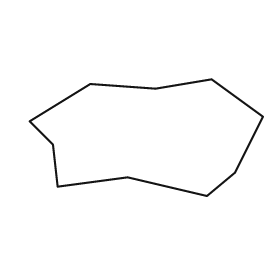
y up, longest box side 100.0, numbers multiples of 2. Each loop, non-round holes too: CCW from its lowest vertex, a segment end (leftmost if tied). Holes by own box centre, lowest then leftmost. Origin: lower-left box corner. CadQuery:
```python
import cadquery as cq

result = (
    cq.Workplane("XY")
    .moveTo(76.0, 0.0)
    .lineTo(88.0, 10.0)
    .lineTo(100.0, 34.0)
    .lineTo(78.0, 50.0)
    .lineTo(54.0, 46.0)
    .lineTo(26.0, 48.0)
    .lineTo(0.0, 32.0)
    .lineTo(10.0, 22.0)
    .lineTo(12.0, 4.0)
    .lineTo(42.0, 8.0)
    .close()
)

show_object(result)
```